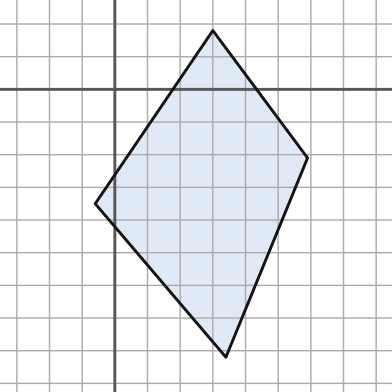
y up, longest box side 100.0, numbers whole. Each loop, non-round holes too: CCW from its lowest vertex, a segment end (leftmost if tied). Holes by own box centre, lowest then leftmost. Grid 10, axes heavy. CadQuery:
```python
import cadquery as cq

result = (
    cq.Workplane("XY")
    .moveTo(34.0, -82.0)
    .lineTo(59.0, -21.0)
    .lineTo(30.0, 18.0)
    .lineTo(-6.0, -35.0)
    .close()
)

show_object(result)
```